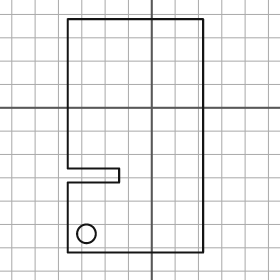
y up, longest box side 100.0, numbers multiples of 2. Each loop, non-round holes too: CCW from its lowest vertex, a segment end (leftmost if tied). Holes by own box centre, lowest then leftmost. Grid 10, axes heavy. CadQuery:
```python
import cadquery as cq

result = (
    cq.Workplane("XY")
    .moveTo(-36.0, -62.0)
    .lineTo(22.0, -62.0)
    .lineTo(22.0, 38.0)
    .lineTo(-36.0, 38.0)
    .lineTo(-36.0, -26.0)
    .lineTo(-14.0, -26.0)
    .lineTo(-14.0, -32.0)
    .lineTo(-36.0, -32.0)
    .close()
    .moveTo(-28.0, -54.0)
    .circle(4.0)
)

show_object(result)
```